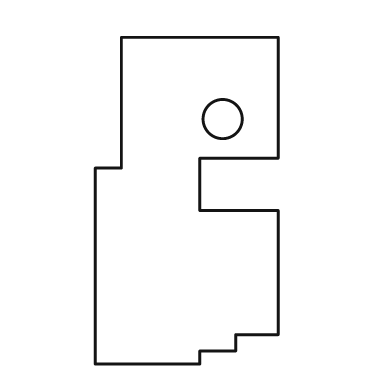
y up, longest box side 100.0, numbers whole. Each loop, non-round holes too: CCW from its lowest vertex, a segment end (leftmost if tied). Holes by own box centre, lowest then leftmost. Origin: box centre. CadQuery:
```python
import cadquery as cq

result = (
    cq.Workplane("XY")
    .moveTo(-28.0, -50.0)
    .lineTo(4.0, -50.0)
    .lineTo(4.0, -46.0)
    .lineTo(15.0, -46.0)
    .lineTo(15.0, -41.0)
    .lineTo(28.0, -41.0)
    .lineTo(28.0, -3.0)
    .lineTo(4.0, -3.0)
    .lineTo(4.0, 13.0)
    .lineTo(28.0, 13.0)
    .lineTo(28.0, 50.0)
    .lineTo(-20.0, 50.0)
    .lineTo(-20.0, 10.0)
    .lineTo(-28.0, 10.0)
    .close()
    .moveTo(11.0, 25.0)
    .circle(6.0)
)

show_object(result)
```